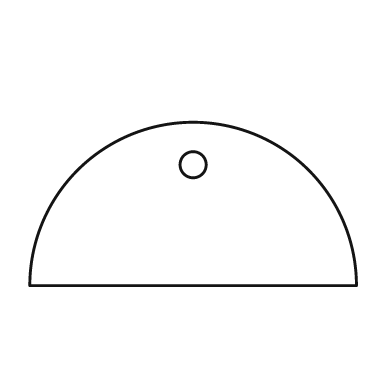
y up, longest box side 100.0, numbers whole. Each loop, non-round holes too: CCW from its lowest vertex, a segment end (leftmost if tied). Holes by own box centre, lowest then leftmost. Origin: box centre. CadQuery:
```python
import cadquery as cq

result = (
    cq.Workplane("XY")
    .moveTo(-50.0, -25.0)
    .lineTo(50.0, -25.0)
    .threePointArc((0.0, 25.0), (-50.0, -25.0))
    .close()
    .moveTo(0.0, 12.0)
    .circle(4.0)
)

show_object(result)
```